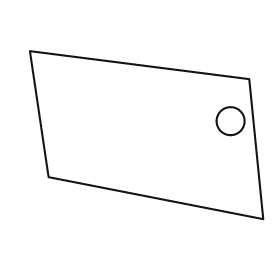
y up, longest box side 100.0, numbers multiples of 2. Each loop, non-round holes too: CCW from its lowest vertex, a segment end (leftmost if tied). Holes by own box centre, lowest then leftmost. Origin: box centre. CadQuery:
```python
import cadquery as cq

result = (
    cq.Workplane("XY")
    .moveTo(50.0, -36.0)
    .lineTo(44.0, 24.0)
    .lineTo(-50.0, 36.0)
    .lineTo(-42.0, -18.0)
    .close()
    .moveTo(36.0, 6.0)
    .circle(6.0)
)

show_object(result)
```